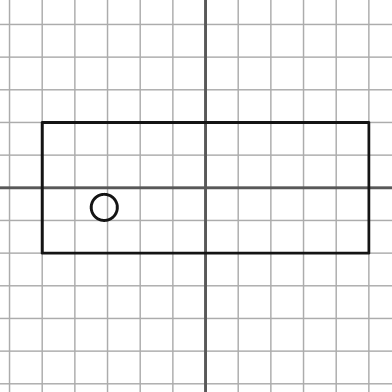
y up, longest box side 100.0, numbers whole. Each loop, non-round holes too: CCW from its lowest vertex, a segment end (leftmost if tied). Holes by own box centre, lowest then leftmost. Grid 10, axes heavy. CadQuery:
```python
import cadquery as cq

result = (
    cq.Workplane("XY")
    .moveTo(-50.0, -20.0)
    .lineTo(50.0, -20.0)
    .lineTo(50.0, 20.0)
    .lineTo(-50.0, 20.0)
    .close()
    .moveTo(-31.0, -6.0)
    .circle(4.0)
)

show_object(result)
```